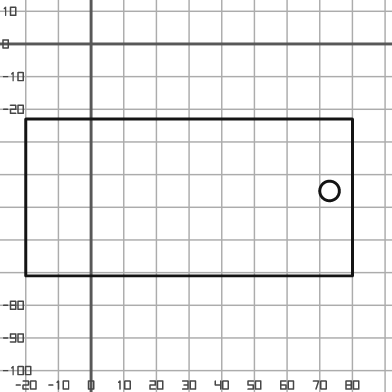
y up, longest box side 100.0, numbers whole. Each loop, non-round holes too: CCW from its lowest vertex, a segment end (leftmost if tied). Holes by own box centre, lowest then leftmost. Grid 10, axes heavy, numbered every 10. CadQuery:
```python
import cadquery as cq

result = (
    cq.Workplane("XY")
    .moveTo(-20.0, -71.0)
    .lineTo(80.0, -71.0)
    .lineTo(80.0, -23.0)
    .lineTo(-20.0, -23.0)
    .close()
    .moveTo(73.0, -45.0)
    .circle(3.0)
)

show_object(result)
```